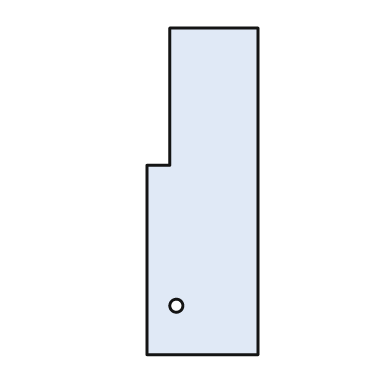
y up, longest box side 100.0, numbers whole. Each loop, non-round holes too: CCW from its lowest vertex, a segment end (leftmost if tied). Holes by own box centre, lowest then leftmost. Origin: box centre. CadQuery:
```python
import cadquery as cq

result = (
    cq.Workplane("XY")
    .moveTo(-17.0, -50.0)
    .lineTo(17.0, -50.0)
    .lineTo(17.0, 50.0)
    .lineTo(-10.0, 50.0)
    .lineTo(-10.0, 8.0)
    .lineTo(-17.0, 8.0)
    .close()
    .moveTo(-8.0, -35.0)
    .circle(2.0)
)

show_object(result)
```